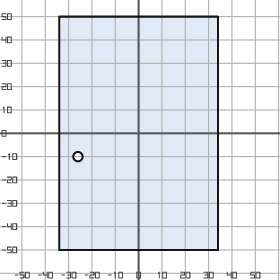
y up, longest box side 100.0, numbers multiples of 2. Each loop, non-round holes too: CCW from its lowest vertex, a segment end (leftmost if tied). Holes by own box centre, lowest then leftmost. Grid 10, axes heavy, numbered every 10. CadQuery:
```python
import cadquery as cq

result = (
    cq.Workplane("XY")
    .moveTo(-34.0, -50.0)
    .lineTo(34.0, -50.0)
    .lineTo(34.0, 50.0)
    .lineTo(-34.0, 50.0)
    .close()
    .moveTo(-26.0, -10.0)
    .circle(2.0)
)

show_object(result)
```